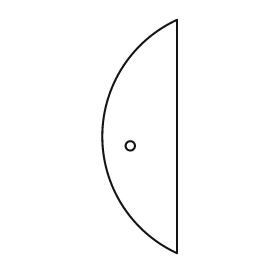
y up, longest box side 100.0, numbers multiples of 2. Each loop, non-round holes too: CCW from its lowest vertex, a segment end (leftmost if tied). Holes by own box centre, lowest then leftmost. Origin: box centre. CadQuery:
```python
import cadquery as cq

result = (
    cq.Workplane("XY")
    .moveTo(16.0, -50.0)
    .lineTo(16.0, 50.0)
    .threePointArc((-16.0, 0.0), (16.0, -50.0))
    .close()
    .moveTo(-4.0, -4.0)
    .circle(2.0)
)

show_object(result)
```